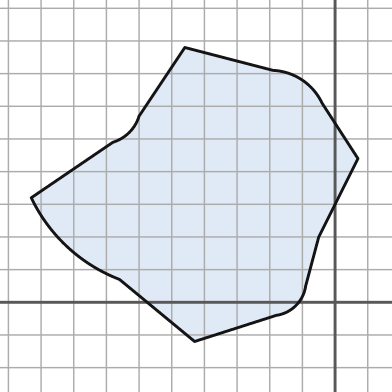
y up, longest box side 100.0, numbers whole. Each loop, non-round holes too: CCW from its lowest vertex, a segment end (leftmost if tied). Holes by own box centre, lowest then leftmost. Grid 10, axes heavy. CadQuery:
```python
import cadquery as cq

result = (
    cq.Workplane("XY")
    .moveTo(-43.0, -12.0)
    .lineTo(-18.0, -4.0)
    .threePointArc((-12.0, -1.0), (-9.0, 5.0))
    .lineTo(-5.0, 20.0)
    .lineTo(7.0, 44.0)
    .lineTo(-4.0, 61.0)
    .threePointArc((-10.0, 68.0), (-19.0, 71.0))
    .lineTo(-46.0, 78.0)
    .lineTo(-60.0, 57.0)
    .threePointArc((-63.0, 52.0), (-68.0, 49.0))
    .lineTo(-93.0, 32.0)
    .threePointArc((-82.0, 17.0), (-66.0, 7.0))
    .close()
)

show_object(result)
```